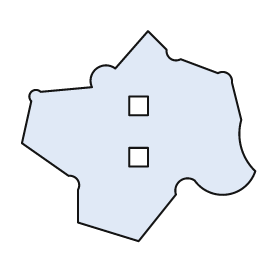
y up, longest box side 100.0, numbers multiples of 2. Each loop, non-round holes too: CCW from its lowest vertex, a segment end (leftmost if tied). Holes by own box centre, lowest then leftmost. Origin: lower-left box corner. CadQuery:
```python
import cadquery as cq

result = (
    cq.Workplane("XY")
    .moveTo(50.0, 0.0)
    .lineTo(66.0, 20.0)
    .threePointArc((68.0, 26.0), (74.0, 26.0))
    .threePointArc((88.0, 20.0), (100.0, 30.0))
    .threePointArc((94.0, 40.0), (94.0, 52.0))
    .lineTo(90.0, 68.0)
    .threePointArc((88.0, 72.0), (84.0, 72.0))
    .lineTo(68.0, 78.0)
    .threePointArc((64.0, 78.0), (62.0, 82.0))
    .lineTo(54.0, 90.0)
    .lineTo(40.0, 74.0)
    .threePointArc((32.0, 74.0), (30.0, 66.0))
    .lineTo(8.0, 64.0)
    .threePointArc((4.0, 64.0), (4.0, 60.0))
    .lineTo(0.0, 42.0)
    .lineTo(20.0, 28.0)
    .threePointArc((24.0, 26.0), (24.0, 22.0))
    .lineTo(24.0, 8.0)
    .close()
    .moveTo(46.0, 32.0)
    .lineTo(54.0, 32.0)
    .lineTo(54.0, 40.0)
    .lineTo(46.0, 40.0)
    .close()
    .moveTo(46.0, 54.0)
    .lineTo(54.0, 54.0)
    .lineTo(54.0, 62.0)
    .lineTo(46.0, 62.0)
    .close()
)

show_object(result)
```